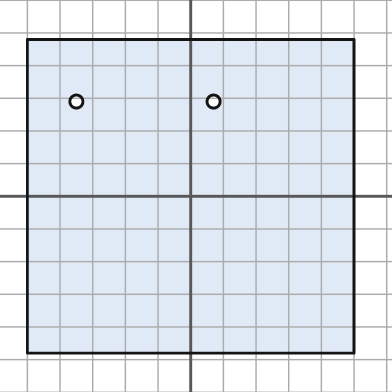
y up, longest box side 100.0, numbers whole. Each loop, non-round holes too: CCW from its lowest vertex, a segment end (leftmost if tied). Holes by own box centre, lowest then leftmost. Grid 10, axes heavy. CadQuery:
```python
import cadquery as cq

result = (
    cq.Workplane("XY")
    .moveTo(-50.0, -48.0)
    .lineTo(50.0, -48.0)
    .lineTo(50.0, 48.0)
    .lineTo(-50.0, 48.0)
    .close()
    .moveTo(-35.0, 29.0)
    .circle(2.0)
    .moveTo(7.0, 29.0)
    .circle(2.0)
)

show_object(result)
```